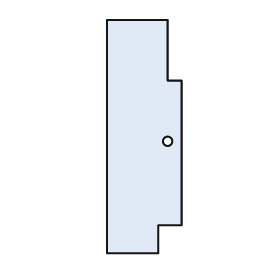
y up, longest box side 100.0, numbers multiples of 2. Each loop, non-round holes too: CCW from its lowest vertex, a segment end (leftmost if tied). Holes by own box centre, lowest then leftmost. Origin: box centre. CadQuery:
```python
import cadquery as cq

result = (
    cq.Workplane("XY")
    .moveTo(-16.0, -50.0)
    .lineTo(6.0, -50.0)
    .lineTo(6.0, -38.0)
    .lineTo(16.0, -38.0)
    .lineTo(16.0, 24.0)
    .lineTo(10.0, 24.0)
    .lineTo(10.0, 50.0)
    .lineTo(-16.0, 50.0)
    .close()
    .moveTo(10.0, -2.0)
    .circle(2.0)
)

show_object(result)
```